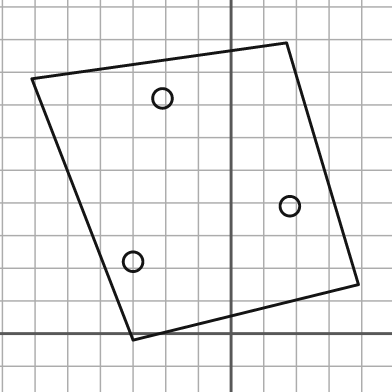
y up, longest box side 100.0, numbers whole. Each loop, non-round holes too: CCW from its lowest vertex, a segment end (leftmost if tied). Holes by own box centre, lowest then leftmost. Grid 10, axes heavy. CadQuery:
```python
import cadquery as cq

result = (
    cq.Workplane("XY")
    .moveTo(-30.0, -2.0)
    .lineTo(39.0, 15.0)
    .lineTo(17.0, 89.0)
    .lineTo(-61.0, 78.0)
    .close()
    .moveTo(-30.0, 22.0)
    .circle(3.0)
    .moveTo(18.0, 39.0)
    .circle(3.0)
    .moveTo(-21.0, 72.0)
    .circle(3.0)
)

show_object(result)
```